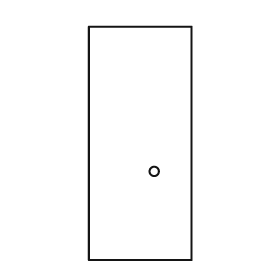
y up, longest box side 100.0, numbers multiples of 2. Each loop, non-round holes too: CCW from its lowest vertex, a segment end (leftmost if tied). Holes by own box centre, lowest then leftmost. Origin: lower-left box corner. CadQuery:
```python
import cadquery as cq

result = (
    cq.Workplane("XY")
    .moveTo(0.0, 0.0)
    .lineTo(44.0, 0.0)
    .lineTo(44.0, 100.0)
    .lineTo(0.0, 100.0)
    .close()
    .moveTo(28.0, 38.0)
    .circle(2.0)
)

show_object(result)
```